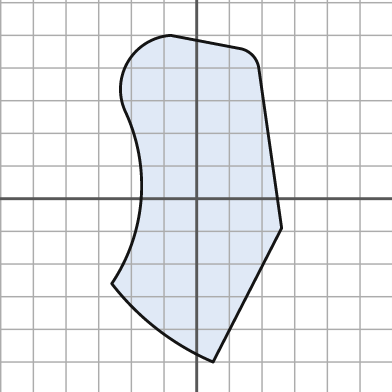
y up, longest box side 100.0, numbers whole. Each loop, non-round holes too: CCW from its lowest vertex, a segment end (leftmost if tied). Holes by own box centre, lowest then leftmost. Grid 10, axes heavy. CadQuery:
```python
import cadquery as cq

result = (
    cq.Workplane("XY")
    .moveTo(5.0, -50.0)
    .lineTo(26.0, -9.0)
    .lineTo(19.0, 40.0)
    .threePointArc((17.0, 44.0), (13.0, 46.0))
    .lineTo(-8.0, 50.0)
    .threePointArc((-21.0, 42.0), (-22.0, 27.0))
    .threePointArc((-17.0, 0.0), (-26.0, -26.0))
    .threePointArc((-12.0, -40.0), (5.0, -50.0))
    .close()
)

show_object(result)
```